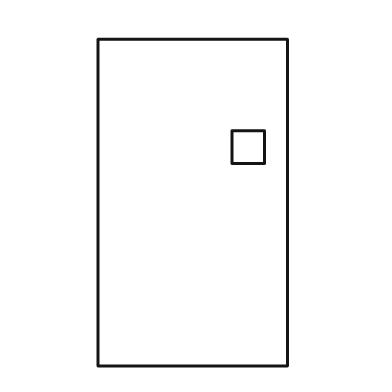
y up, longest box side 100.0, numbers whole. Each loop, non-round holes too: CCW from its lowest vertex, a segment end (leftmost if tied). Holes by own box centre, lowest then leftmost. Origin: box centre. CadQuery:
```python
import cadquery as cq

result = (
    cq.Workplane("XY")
    .moveTo(-29.0, -50.0)
    .lineTo(29.0, -50.0)
    .lineTo(29.0, 50.0)
    .lineTo(-29.0, 50.0)
    .close()
    .moveTo(12.0, 12.0)
    .lineTo(22.0, 12.0)
    .lineTo(22.0, 22.0)
    .lineTo(12.0, 22.0)
    .close()
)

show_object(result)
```